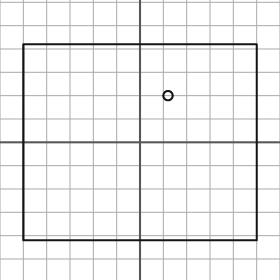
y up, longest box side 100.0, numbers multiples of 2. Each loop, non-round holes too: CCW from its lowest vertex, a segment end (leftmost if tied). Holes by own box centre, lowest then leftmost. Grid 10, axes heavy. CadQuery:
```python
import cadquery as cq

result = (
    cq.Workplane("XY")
    .moveTo(-50.0, -42.0)
    .lineTo(50.0, -42.0)
    .lineTo(50.0, 42.0)
    .lineTo(-50.0, 42.0)
    .close()
    .moveTo(12.0, 20.0)
    .circle(2.0)
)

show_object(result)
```